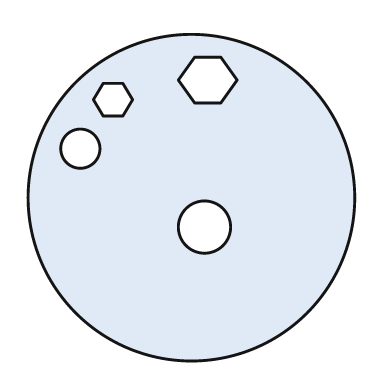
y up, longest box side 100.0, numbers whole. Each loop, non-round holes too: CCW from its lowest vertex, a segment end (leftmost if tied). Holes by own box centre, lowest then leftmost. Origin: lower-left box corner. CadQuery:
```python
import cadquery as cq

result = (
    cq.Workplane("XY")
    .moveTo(50.0, 50.0)
    .circle(50.0)
    .moveTo(54.0, 41.0)
    .circle(8.0)
    .moveTo(16.0, 65.0)
    .circle(6.0)
    .moveTo(23.0, 75.0)
    .lineTo(29.0, 75.0)
    .lineTo(32.0, 80.0)
    .lineTo(29.0, 85.0)
    .lineTo(23.0, 85.0)
    .lineTo(20.0, 80.0)
    .close()
    .moveTo(51.0, 79.0)
    .lineTo(59.0, 79.0)
    .lineTo(64.0, 86.0)
    .lineTo(59.0, 93.0)
    .lineTo(51.0, 93.0)
    .lineTo(46.0, 86.0)
    .close()
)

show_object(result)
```